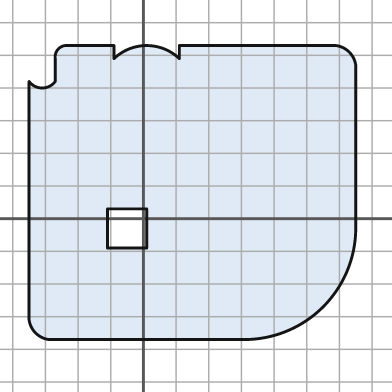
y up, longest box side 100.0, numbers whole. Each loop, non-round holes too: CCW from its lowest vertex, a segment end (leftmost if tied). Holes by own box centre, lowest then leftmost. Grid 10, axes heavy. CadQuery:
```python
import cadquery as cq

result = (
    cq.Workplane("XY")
    .moveTo(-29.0, -37.0)
    .lineTo(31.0, -37.0)
    .threePointArc((55.0, -27.0), (65.0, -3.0))
    .lineTo(65.0, 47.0)
    .threePointArc((63.0, 51.0), (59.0, 53.0))
    .lineTo(11.0, 53.0)
    .lineTo(11.0, 49.0)
    .threePointArc((1.0, 53.0), (-9.0, 49.0))
    .lineTo(-9.0, 53.0)
    .lineTo(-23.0, 53.0)
    .threePointArc((-26.0, 52.0), (-27.0, 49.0))
    .lineTo(-27.0, 42.0)
    .threePointArc((-31.0, 40.0), (-35.0, 42.0))
    .lineTo(-35.0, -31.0)
    .threePointArc((-33.0, -35.0), (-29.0, -37.0))
    .close()
    .moveTo(-11.0, -9.0)
    .lineTo(1.0, -9.0)
    .lineTo(1.0, 3.0)
    .lineTo(-11.0, 3.0)
    .close()
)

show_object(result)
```